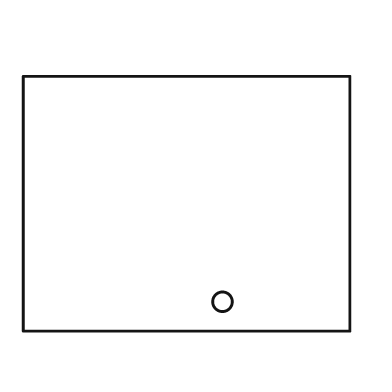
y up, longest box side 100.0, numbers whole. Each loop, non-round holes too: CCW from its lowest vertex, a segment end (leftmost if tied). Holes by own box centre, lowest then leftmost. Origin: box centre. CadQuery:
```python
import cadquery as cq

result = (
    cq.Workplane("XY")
    .moveTo(-50.0, -39.0)
    .lineTo(50.0, -39.0)
    .lineTo(50.0, 39.0)
    .lineTo(-50.0, 39.0)
    .close()
    .moveTo(11.0, -30.0)
    .circle(3.0)
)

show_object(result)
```